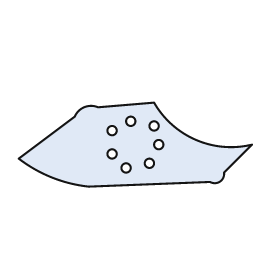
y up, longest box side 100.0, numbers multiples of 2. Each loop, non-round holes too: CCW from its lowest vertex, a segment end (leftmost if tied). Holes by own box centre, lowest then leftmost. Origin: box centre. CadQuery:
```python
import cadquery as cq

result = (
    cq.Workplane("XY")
    .moveTo(-20.0, -18.0)
    .lineTo(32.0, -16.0)
    .threePointArc((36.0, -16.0), (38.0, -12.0))
    .lineTo(50.0, 0.0)
    .threePointArc((26.0, 2.0), (8.0, 18.0))
    .lineTo(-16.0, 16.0)
    .threePointArc((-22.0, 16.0), (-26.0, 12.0))
    .lineTo(-50.0, -6.0)
    .threePointArc((-36.0, -14.0), (-20.0, -18.0))
    .close()
    .moveTo(-4.0, -10.0)
    .circle(2.0)
    .moveTo(6.0, -8.0)
    .circle(2.0)
    .moveTo(-10.0, -4.0)
    .circle(2.0)
    .moveTo(10.0, 0.0)
    .circle(2.0)
    .moveTo(-10.0, 6.0)
    .circle(2.0)
    .moveTo(8.0, 8.0)
    .circle(2.0)
    .moveTo(-2.0, 10.0)
    .circle(2.0)
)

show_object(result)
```